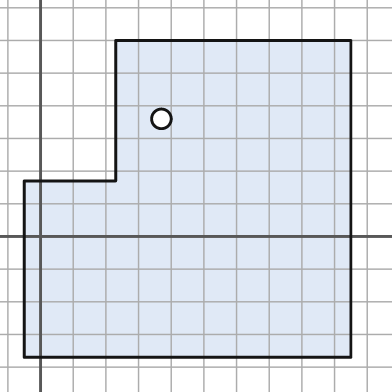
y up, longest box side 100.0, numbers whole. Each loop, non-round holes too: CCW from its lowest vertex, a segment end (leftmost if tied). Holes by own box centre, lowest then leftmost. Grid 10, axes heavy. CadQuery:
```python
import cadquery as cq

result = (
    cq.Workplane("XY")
    .moveTo(-5.0, -37.0)
    .lineTo(95.0, -37.0)
    .lineTo(95.0, 60.0)
    .lineTo(23.0, 60.0)
    .lineTo(23.0, 17.0)
    .lineTo(-5.0, 17.0)
    .close()
    .moveTo(37.0, 36.0)
    .circle(3.0)
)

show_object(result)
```